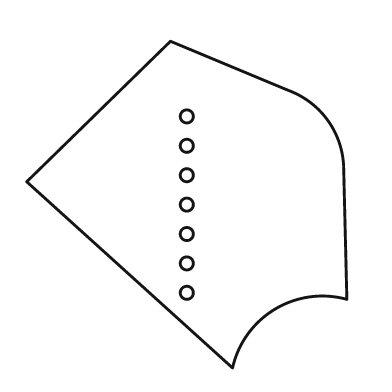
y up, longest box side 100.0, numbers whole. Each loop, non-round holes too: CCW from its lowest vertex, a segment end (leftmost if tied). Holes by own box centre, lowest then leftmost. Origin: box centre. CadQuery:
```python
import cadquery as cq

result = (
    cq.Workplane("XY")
    .moveTo(14.0, -50.0)
    .threePointArc((27.0, -32.0), (49.0, -29.0))
    .lineTo(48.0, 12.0)
    .threePointArc((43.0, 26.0), (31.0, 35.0))
    .lineTo(-5.0, 50.0)
    .lineTo(-49.0, 7.0)
    .close()
    .moveTo(0.0, -27.0)
    .circle(2.0)
    .moveTo(0.0, -18.0)
    .circle(2.0)
    .moveTo(0.0, -9.0)
    .circle(2.0)
    .moveTo(0.0, 0.0)
    .circle(2.0)
    .moveTo(0.0, 9.0)
    .circle(2.0)
    .moveTo(0.0, 18.0)
    .circle(2.0)
    .moveTo(0.0, 27.0)
    .circle(2.0)
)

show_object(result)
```